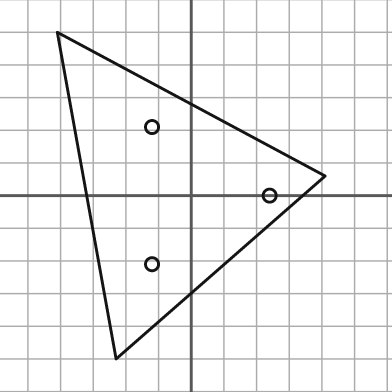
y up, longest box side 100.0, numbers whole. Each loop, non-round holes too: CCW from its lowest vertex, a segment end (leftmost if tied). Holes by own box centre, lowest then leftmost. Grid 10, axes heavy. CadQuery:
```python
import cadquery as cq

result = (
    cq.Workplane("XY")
    .moveTo(-23.0, -50.0)
    .lineTo(41.0, 6.0)
    .lineTo(-41.0, 50.0)
    .close()
    .moveTo(-12.0, -21.0)
    .circle(2.0)
    .moveTo(24.0, 0.0)
    .circle(2.0)
    .moveTo(-12.0, 21.0)
    .circle(2.0)
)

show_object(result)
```